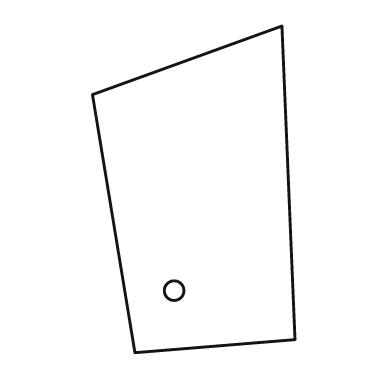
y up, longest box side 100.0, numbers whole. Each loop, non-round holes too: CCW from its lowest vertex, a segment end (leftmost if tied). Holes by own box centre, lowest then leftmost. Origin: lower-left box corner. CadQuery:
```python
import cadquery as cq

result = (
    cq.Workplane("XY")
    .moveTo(13.0, 0.0)
    .lineTo(62.0, 4.0)
    .lineTo(58.0, 100.0)
    .lineTo(0.0, 79.0)
    .close()
    .moveTo(25.0, 19.0)
    .circle(3.0)
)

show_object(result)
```